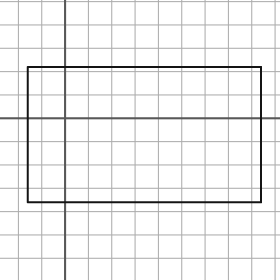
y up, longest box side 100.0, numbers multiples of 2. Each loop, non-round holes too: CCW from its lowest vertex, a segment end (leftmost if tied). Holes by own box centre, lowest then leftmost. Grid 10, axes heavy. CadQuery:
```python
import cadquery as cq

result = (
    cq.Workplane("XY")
    .moveTo(-16.0, -36.0)
    .lineTo(84.0, -36.0)
    .lineTo(84.0, 22.0)
    .lineTo(-16.0, 22.0)
    .close()
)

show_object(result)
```